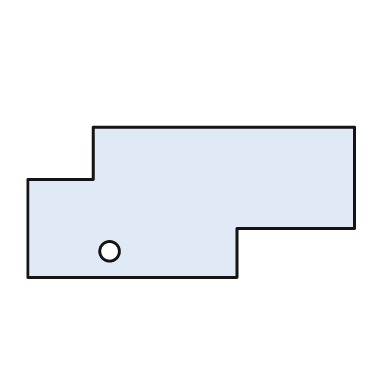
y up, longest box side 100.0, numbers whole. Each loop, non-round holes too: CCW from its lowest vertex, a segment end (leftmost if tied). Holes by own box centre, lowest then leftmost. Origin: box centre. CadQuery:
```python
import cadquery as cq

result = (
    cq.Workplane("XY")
    .moveTo(-50.0, -23.0)
    .lineTo(14.0, -23.0)
    .lineTo(14.0, -8.0)
    .lineTo(50.0, -8.0)
    .lineTo(50.0, 23.0)
    .lineTo(-30.0, 23.0)
    .lineTo(-30.0, 7.0)
    .lineTo(-50.0, 7.0)
    .close()
    .moveTo(-25.0, -15.0)
    .circle(3.0)
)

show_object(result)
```